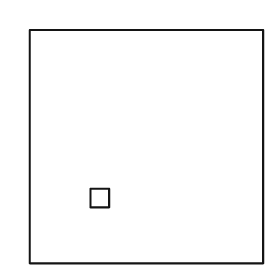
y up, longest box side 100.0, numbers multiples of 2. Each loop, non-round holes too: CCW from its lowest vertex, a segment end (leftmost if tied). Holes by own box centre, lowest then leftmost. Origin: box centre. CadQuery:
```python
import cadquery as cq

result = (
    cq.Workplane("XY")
    .moveTo(-50.0, -50.0)
    .lineTo(50.0, -50.0)
    .lineTo(50.0, 50.0)
    .lineTo(-50.0, 50.0)
    .close()
    .moveTo(-24.0, -26.0)
    .lineTo(-16.0, -26.0)
    .lineTo(-16.0, -18.0)
    .lineTo(-24.0, -18.0)
    .close()
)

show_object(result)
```